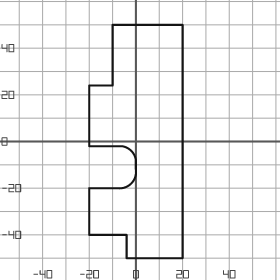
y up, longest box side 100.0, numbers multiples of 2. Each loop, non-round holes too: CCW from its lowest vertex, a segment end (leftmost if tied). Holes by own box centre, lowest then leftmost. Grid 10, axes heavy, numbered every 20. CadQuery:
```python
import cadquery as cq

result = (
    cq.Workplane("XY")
    .moveTo(-4.0, -50.0)
    .lineTo(20.0, -50.0)
    .lineTo(20.0, 50.0)
    .lineTo(-10.0, 50.0)
    .lineTo(-10.0, 24.0)
    .lineTo(-20.0, 24.0)
    .lineTo(-20.0, -2.0)
    .lineTo(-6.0, -2.0)
    .threePointArc((-2.0, -4.0), (0.0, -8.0))
    .lineTo(0.0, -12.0)
    .threePointArc((-2.0, -18.0), (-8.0, -20.0))
    .lineTo(-20.0, -20.0)
    .lineTo(-20.0, -40.0)
    .lineTo(-4.0, -40.0)
    .close()
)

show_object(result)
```